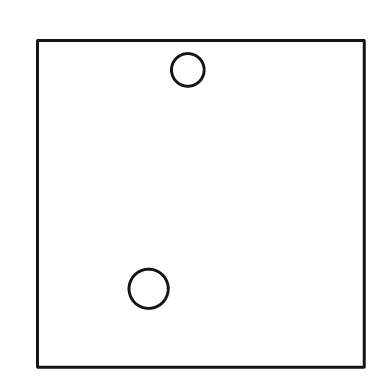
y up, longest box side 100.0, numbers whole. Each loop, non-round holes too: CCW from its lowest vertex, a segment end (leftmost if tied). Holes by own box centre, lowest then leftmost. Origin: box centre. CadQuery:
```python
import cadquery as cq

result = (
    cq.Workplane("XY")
    .moveTo(-50.0, -50.0)
    .lineTo(50.0, -50.0)
    .lineTo(50.0, 50.0)
    .lineTo(-50.0, 50.0)
    .close()
    .moveTo(-16.0, -26.0)
    .circle(6.0)
    .moveTo(-4.0, 41.0)
    .circle(5.0)
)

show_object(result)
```